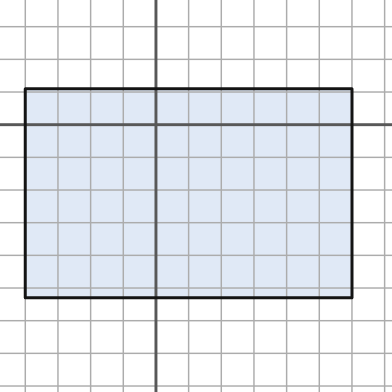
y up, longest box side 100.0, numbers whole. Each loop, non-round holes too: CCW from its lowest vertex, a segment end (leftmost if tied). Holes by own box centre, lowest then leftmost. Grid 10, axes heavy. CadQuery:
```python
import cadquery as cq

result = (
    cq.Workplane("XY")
    .moveTo(-40.0, -53.0)
    .lineTo(60.0, -53.0)
    .lineTo(60.0, 11.0)
    .lineTo(-40.0, 11.0)
    .close()
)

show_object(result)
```